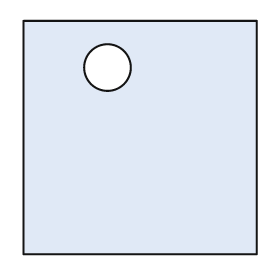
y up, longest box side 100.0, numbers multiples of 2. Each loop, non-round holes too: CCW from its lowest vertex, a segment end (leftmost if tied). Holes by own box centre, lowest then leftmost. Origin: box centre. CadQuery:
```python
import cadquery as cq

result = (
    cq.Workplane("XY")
    .moveTo(-50.0, -50.0)
    .lineTo(50.0, -50.0)
    .lineTo(50.0, 50.0)
    .lineTo(-50.0, 50.0)
    .close()
    .moveTo(-14.0, 30.0)
    .circle(10.0)
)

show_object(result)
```